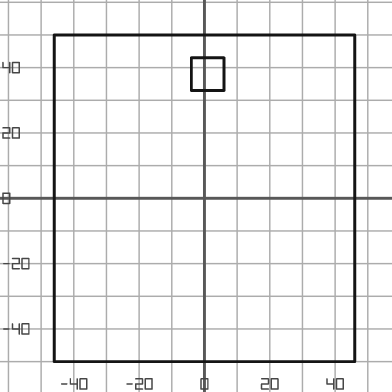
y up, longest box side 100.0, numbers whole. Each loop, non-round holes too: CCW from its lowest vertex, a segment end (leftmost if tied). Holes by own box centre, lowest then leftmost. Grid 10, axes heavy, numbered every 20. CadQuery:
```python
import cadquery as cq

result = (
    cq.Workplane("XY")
    .moveTo(-46.0, -50.0)
    .lineTo(46.0, -50.0)
    .lineTo(46.0, 50.0)
    .lineTo(-46.0, 50.0)
    .close()
    .moveTo(-4.0, 33.0)
    .lineTo(6.0, 33.0)
    .lineTo(6.0, 43.0)
    .lineTo(-4.0, 43.0)
    .close()
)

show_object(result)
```